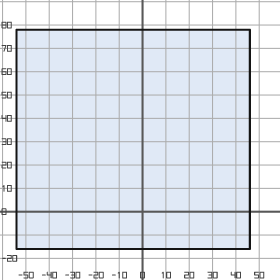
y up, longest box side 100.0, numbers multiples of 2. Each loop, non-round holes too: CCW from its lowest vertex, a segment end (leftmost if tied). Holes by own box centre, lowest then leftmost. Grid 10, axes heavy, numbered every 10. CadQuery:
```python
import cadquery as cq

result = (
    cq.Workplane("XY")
    .moveTo(-54.0, -16.0)
    .lineTo(46.0, -16.0)
    .lineTo(46.0, 78.0)
    .lineTo(-54.0, 78.0)
    .close()
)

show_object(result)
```